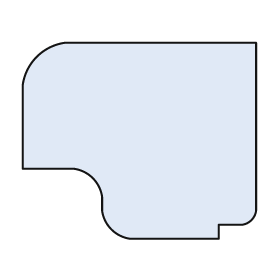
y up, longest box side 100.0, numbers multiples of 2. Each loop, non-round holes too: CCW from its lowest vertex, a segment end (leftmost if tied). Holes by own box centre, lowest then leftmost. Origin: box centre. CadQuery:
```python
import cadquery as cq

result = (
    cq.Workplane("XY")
    .moveTo(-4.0, -42.0)
    .lineTo(34.0, -42.0)
    .lineTo(34.0, -36.0)
    .lineTo(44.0, -36.0)
    .threePointArc((48.0, -34.0), (50.0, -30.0))
    .lineTo(50.0, 42.0)
    .lineTo(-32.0, 42.0)
    .threePointArc((-44.0, 36.0), (-50.0, 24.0))
    .lineTo(-50.0, -12.0)
    .lineTo(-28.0, -12.0)
    .threePointArc((-20.0, -16.0), (-16.0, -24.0))
    .lineTo(-16.0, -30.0)
    .threePointArc((-12.0, -38.0), (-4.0, -42.0))
    .close()
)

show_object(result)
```